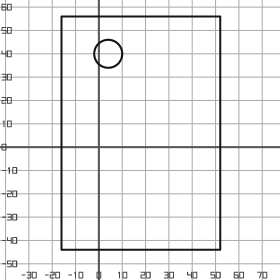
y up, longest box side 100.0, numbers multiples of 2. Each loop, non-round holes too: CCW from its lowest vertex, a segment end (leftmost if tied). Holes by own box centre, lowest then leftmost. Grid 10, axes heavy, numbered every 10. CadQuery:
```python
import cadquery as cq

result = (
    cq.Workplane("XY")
    .moveTo(-16.0, -44.0)
    .lineTo(52.0, -44.0)
    .lineTo(52.0, 56.0)
    .lineTo(-16.0, 56.0)
    .close()
    .moveTo(4.0, 40.0)
    .circle(6.0)
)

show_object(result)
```